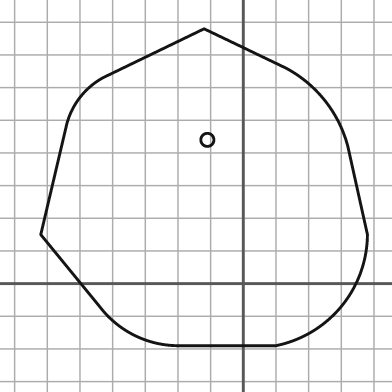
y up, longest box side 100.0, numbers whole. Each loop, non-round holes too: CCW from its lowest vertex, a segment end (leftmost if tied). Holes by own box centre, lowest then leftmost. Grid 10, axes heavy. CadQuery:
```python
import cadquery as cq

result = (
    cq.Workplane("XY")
    .moveTo(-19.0, -19.0)
    .lineTo(10.0, -19.0)
    .threePointArc((30.0, -7.0), (38.0, 15.0))
    .lineTo(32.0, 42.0)
    .threePointArc((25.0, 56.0), (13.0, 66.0))
    .lineTo(-12.0, 78.0)
    .lineTo(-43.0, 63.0)
    .threePointArc((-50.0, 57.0), (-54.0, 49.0))
    .lineTo(-62.0, 15.0)
    .lineTo(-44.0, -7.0)
    .threePointArc((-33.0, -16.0), (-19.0, -19.0))
    .close()
    .moveTo(-11.0, 44.0)
    .circle(2.0)
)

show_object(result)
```